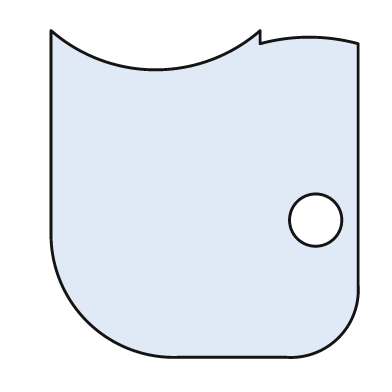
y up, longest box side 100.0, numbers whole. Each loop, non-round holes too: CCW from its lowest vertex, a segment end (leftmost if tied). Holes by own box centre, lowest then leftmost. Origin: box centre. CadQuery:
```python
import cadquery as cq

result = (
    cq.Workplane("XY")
    .moveTo(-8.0, -50.0)
    .lineTo(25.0, -50.0)
    .threePointArc((41.0, -44.0), (47.0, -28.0))
    .lineTo(47.0, 46.0)
    .threePointArc((32.0, 48.0), (17.0, 46.0))
    .lineTo(17.0, 50.0)
    .threePointArc((-15.0, 38.0), (-47.0, 50.0))
    .lineTo(-47.0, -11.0)
    .threePointArc((-36.0, -39.0), (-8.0, -50.0))
    .close()
    .moveTo(34.0, -8.0)
    .circle(8.0)
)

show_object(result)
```